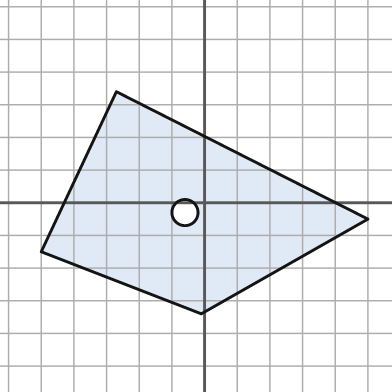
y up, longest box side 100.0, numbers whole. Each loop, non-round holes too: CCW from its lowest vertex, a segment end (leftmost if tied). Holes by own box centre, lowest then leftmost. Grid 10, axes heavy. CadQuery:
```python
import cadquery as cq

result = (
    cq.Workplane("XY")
    .moveTo(-1.0, -34.0)
    .lineTo(50.0, -5.0)
    .lineTo(-27.0, 34.0)
    .lineTo(-50.0, -15.0)
    .close()
    .moveTo(-6.0, -3.0)
    .circle(4.0)
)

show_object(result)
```